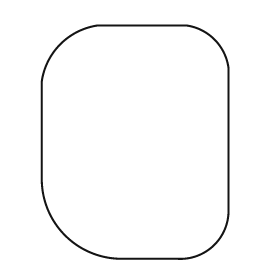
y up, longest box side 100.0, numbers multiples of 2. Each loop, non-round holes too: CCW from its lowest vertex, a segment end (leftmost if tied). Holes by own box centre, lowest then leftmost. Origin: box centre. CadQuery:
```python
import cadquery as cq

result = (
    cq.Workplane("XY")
    .moveTo(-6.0, -50.0)
    .lineTo(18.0, -50.0)
    .threePointArc((34.0, -44.0), (40.0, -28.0))
    .lineTo(40.0, 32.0)
    .threePointArc((34.0, 44.0), (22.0, 50.0))
    .lineTo(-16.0, 50.0)
    .threePointArc((-32.0, 42.0), (-40.0, 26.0))
    .lineTo(-40.0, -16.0)
    .threePointArc((-30.0, -40.0), (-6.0, -50.0))
    .close()
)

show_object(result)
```